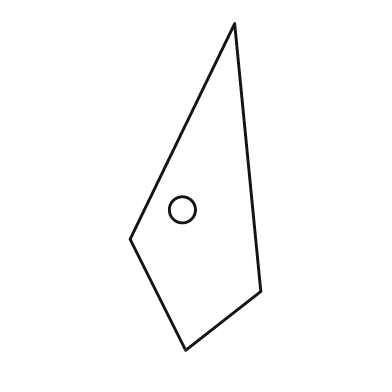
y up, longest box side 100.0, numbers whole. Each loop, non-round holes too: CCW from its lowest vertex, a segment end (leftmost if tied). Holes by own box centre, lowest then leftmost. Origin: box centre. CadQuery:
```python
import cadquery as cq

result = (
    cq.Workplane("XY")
    .moveTo(-3.0, -50.0)
    .lineTo(20.0, -32.0)
    .lineTo(12.0, 50.0)
    .lineTo(-20.0, -16.0)
    .close()
    .moveTo(-4.0, -7.0)
    .circle(4.0)
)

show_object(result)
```